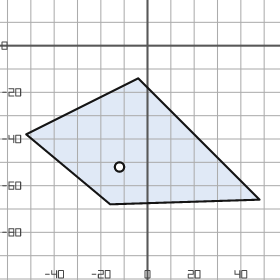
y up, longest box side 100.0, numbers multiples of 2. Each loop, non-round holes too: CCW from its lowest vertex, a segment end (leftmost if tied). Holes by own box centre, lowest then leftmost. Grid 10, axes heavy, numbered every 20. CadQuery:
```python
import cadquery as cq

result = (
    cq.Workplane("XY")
    .moveTo(-16.0, -68.0)
    .lineTo(48.0, -66.0)
    .lineTo(-4.0, -14.0)
    .lineTo(-52.0, -38.0)
    .close()
    .moveTo(-12.0, -52.0)
    .circle(2.0)
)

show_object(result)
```